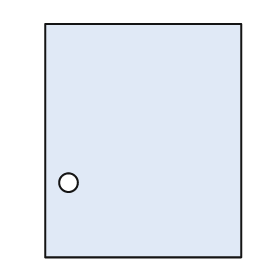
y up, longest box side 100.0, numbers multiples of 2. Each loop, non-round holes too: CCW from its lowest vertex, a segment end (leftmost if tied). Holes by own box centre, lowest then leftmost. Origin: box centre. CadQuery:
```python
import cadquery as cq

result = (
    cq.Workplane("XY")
    .moveTo(-42.0, -50.0)
    .lineTo(42.0, -50.0)
    .lineTo(42.0, 50.0)
    .lineTo(-42.0, 50.0)
    .close()
    .moveTo(-32.0, -18.0)
    .circle(4.0)
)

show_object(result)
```